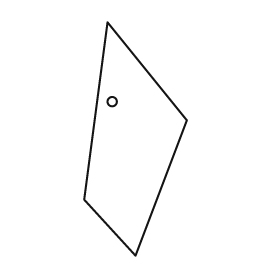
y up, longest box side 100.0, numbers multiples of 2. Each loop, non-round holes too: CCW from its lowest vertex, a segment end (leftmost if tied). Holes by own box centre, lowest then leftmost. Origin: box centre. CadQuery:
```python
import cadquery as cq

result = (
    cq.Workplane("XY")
    .moveTo(0.0, -50.0)
    .lineTo(22.0, 8.0)
    .lineTo(-12.0, 50.0)
    .lineTo(-22.0, -26.0)
    .close()
    .moveTo(-10.0, 16.0)
    .circle(2.0)
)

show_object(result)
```